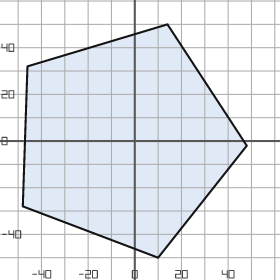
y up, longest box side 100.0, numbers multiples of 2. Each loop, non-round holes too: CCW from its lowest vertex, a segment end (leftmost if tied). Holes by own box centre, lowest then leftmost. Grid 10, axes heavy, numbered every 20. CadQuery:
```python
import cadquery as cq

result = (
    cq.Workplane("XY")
    .moveTo(10.0, -50.0)
    .lineTo(48.0, -2.0)
    .lineTo(14.0, 50.0)
    .lineTo(-46.0, 32.0)
    .lineTo(-48.0, -28.0)
    .close()
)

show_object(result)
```